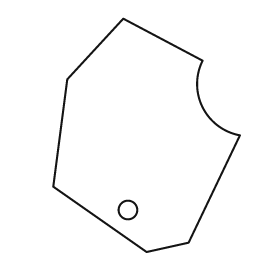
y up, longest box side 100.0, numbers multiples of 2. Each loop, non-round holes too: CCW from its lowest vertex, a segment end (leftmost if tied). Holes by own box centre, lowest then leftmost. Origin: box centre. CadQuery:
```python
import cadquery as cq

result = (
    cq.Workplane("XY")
    .moveTo(0.0, -50.0)
    .lineTo(18.0, -46.0)
    .lineTo(40.0, 0.0)
    .threePointArc((24.0, 12.0), (24.0, 32.0))
    .lineTo(-10.0, 50.0)
    .lineTo(-34.0, 24.0)
    .lineTo(-40.0, -22.0)
    .close()
    .moveTo(-8.0, -32.0)
    .circle(4.0)
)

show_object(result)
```